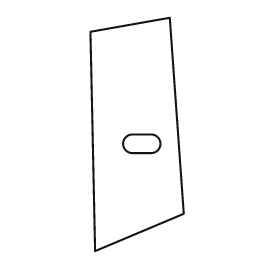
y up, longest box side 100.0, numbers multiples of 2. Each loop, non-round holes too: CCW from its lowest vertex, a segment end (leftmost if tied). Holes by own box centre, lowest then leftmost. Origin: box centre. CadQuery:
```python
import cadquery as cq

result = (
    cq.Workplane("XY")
    .moveTo(-18.0, -50.0)
    .lineTo(20.0, -34.0)
    .lineTo(14.0, 50.0)
    .lineTo(-20.0, 44.0)
    .close()
    .moveTo(-2.0, -8.0)
    .lineTo(6.0, -8.0)
    .threePointArc((10.0, -4.0), (6.0, 0.0))
    .lineTo(-2.0, 0.0)
    .threePointArc((-6.0, -4.0), (-2.0, -8.0))
    .close()
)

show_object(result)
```